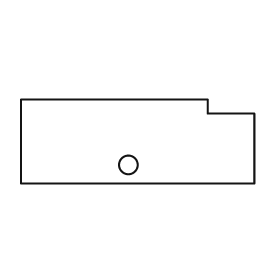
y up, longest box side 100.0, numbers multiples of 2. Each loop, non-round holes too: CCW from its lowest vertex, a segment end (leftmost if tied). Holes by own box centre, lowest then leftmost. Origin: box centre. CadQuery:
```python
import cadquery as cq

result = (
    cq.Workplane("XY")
    .moveTo(-50.0, -18.0)
    .lineTo(50.0, -18.0)
    .lineTo(50.0, 12.0)
    .lineTo(30.0, 12.0)
    .lineTo(30.0, 18.0)
    .lineTo(-50.0, 18.0)
    .close()
    .moveTo(-4.0, -10.0)
    .circle(4.0)
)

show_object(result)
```